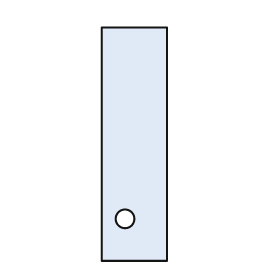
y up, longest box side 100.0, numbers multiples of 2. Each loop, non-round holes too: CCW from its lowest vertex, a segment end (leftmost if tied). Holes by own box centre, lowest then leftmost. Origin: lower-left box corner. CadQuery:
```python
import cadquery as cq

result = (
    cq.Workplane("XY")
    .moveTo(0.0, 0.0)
    .lineTo(28.0, 0.0)
    .lineTo(28.0, 100.0)
    .lineTo(0.0, 100.0)
    .close()
    .moveTo(10.0, 18.0)
    .circle(4.0)
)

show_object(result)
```